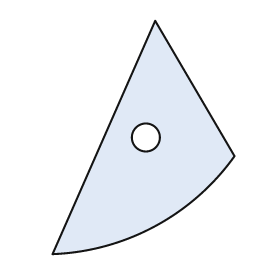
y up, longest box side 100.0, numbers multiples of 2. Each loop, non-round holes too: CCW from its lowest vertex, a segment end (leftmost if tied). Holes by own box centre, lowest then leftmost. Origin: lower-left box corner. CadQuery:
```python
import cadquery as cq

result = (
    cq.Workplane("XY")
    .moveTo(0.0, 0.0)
    .threePointArc((44.0, 12.0), (78.0, 42.0))
    .lineTo(44.0, 100.0)
    .close()
    .moveTo(40.0, 50.0)
    .circle(6.0)
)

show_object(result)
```